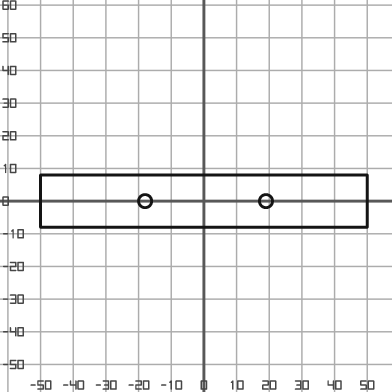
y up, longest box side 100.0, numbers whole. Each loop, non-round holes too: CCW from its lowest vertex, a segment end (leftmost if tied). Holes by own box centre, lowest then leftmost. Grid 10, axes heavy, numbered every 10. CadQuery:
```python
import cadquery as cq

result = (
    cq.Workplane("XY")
    .moveTo(-50.0, -8.0)
    .lineTo(50.0, -8.0)
    .lineTo(50.0, 8.0)
    .lineTo(-50.0, 8.0)
    .close()
    .moveTo(-18.0, 0.0)
    .circle(2.0)
    .moveTo(19.0, 0.0)
    .circle(2.0)
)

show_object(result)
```